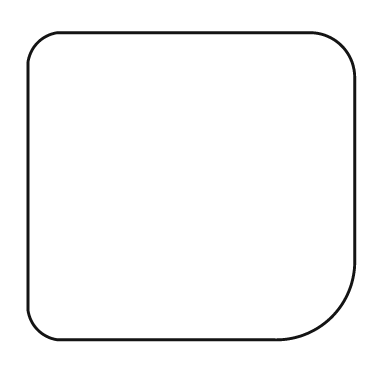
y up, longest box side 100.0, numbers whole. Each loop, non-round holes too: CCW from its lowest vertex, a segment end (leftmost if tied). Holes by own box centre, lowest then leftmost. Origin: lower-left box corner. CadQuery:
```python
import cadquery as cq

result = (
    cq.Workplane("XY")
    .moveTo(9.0, 0.0)
    .lineTo(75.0, 0.0)
    .threePointArc((93.0, 7.0), (100.0, 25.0))
    .lineTo(100.0, 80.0)
    .threePointArc((96.0, 90.0), (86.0, 94.0))
    .lineTo(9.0, 94.0)
    .threePointArc((3.0, 91.0), (0.0, 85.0))
    .lineTo(0.0, 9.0)
    .threePointArc((3.0, 3.0), (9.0, 0.0))
    .close()
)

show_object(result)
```